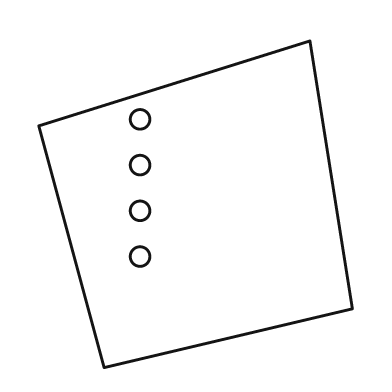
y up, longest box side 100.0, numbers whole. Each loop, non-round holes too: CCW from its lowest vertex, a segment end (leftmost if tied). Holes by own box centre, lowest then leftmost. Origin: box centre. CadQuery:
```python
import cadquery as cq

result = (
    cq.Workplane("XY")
    .moveTo(-28.0, -50.0)
    .lineTo(48.0, -32.0)
    .lineTo(35.0, 50.0)
    .lineTo(-48.0, 24.0)
    .close()
    .moveTo(-17.0, -16.0)
    .circle(3.0)
    .moveTo(-17.0, -2.0)
    .circle(3.0)
    .moveTo(-17.0, 12.0)
    .circle(3.0)
    .moveTo(-17.0, 26.0)
    .circle(3.0)
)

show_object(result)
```